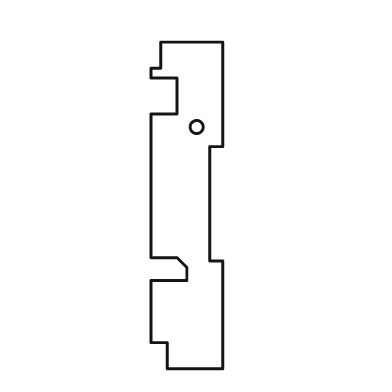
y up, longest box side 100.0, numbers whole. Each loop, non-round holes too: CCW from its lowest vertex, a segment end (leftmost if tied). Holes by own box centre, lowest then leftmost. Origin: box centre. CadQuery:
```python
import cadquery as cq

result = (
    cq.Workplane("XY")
    .moveTo(-6.0, -50.0)
    .lineTo(11.0, -50.0)
    .lineTo(11.0, -17.0)
    .lineTo(7.0, -17.0)
    .lineTo(7.0, 18.0)
    .lineTo(11.0, 18.0)
    .lineTo(11.0, 50.0)
    .lineTo(-8.0, 50.0)
    .lineTo(-8.0, 42.0)
    .lineTo(-11.0, 42.0)
    .lineTo(-11.0, 39.0)
    .lineTo(-3.0, 39.0)
    .lineTo(-3.0, 28.0)
    .lineTo(-11.0, 28.0)
    .lineTo(-11.0, -16.0)
    .lineTo(-3.0, -16.0)
    .lineTo(0.0, -19.0)
    .lineTo(0.0, -23.0)
    .lineTo(-11.0, -23.0)
    .lineTo(-11.0, -42.0)
    .lineTo(-6.0, -42.0)
    .close()
    .moveTo(3.0, 24.0)
    .circle(2.0)
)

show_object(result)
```